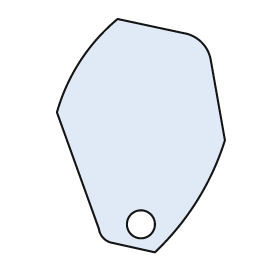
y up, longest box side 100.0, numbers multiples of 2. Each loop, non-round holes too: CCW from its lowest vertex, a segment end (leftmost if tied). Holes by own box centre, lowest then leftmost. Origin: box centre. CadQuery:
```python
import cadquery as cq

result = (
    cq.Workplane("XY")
    .moveTo(6.0, -50.0)
    .threePointArc((24.0, -28.0), (36.0, -2.0))
    .lineTo(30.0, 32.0)
    .threePointArc((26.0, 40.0), (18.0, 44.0))
    .lineTo(-10.0, 50.0)
    .threePointArc((-26.0, 32.0), (-36.0, 10.0))
    .lineTo(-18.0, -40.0)
    .threePointArc((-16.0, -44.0), (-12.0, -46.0))
    .close()
    .moveTo(0.0, -38.0)
    .circle(6.0)
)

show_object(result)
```